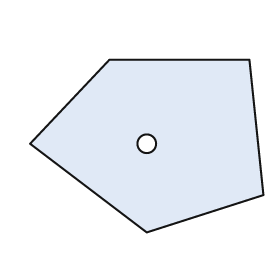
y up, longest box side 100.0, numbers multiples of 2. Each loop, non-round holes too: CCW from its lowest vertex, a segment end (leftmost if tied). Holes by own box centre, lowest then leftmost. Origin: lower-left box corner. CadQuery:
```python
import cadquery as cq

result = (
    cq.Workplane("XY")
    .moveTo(50.0, 0.0)
    .lineTo(100.0, 16.0)
    .lineTo(94.0, 74.0)
    .lineTo(34.0, 74.0)
    .lineTo(0.0, 38.0)
    .close()
    .moveTo(50.0, 38.0)
    .circle(4.0)
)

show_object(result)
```